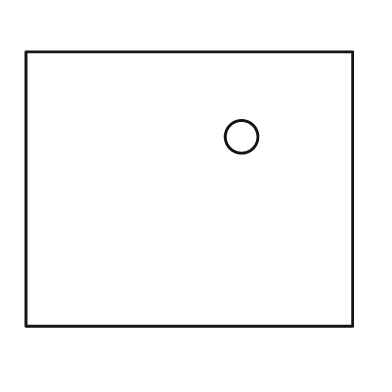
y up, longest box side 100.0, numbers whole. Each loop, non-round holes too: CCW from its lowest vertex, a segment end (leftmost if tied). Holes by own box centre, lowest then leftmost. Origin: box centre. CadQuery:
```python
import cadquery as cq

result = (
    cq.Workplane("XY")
    .moveTo(-50.0, -42.0)
    .lineTo(50.0, -42.0)
    .lineTo(50.0, 42.0)
    .lineTo(-50.0, 42.0)
    .close()
    .moveTo(16.0, 16.0)
    .circle(5.0)
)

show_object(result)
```